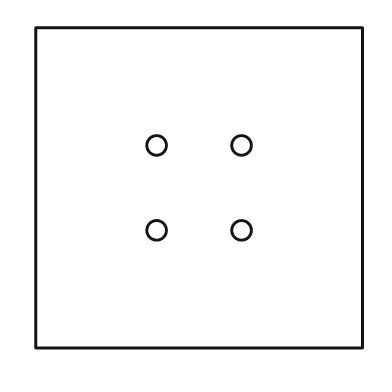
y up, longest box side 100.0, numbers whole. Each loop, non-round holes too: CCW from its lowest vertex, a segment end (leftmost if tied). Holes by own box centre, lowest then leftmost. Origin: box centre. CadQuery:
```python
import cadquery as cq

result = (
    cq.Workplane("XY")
    .moveTo(-50.0, -49.0)
    .lineTo(50.0, -49.0)
    .lineTo(50.0, 49.0)
    .lineTo(-50.0, 49.0)
    .close()
    .moveTo(-13.0, -13.0)
    .circle(3.0)
    .moveTo(13.0, -13.0)
    .circle(3.0)
    .moveTo(-13.0, 13.0)
    .circle(3.0)
    .moveTo(13.0, 13.0)
    .circle(3.0)
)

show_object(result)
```